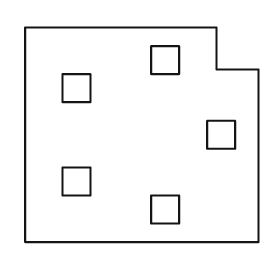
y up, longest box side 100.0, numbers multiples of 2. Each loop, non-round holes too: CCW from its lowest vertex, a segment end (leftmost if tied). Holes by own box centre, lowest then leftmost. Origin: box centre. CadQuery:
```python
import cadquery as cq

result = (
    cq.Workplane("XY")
    .moveTo(-50.0, -46.0)
    .lineTo(50.0, -46.0)
    .lineTo(50.0, 28.0)
    .lineTo(32.0, 28.0)
    .lineTo(32.0, 46.0)
    .lineTo(-50.0, 46.0)
    .close()
    .moveTo(4.0, -38.0)
    .lineTo(16.0, -38.0)
    .lineTo(16.0, -26.0)
    .lineTo(4.0, -26.0)
    .close()
    .moveTo(-34.0, -26.0)
    .lineTo(-22.0, -26.0)
    .lineTo(-22.0, -14.0)
    .lineTo(-34.0, -14.0)
    .close()
    .moveTo(28.0, -6.0)
    .lineTo(40.0, -6.0)
    .lineTo(40.0, 6.0)
    .lineTo(28.0, 6.0)
    .close()
    .moveTo(-34.0, 14.0)
    .lineTo(-22.0, 14.0)
    .lineTo(-22.0, 26.0)
    .lineTo(-34.0, 26.0)
    .close()
    .moveTo(4.0, 26.0)
    .lineTo(16.0, 26.0)
    .lineTo(16.0, 38.0)
    .lineTo(4.0, 38.0)
    .close()
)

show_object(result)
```